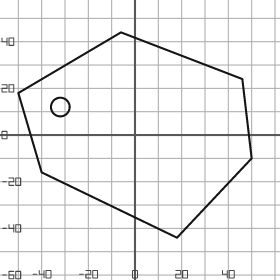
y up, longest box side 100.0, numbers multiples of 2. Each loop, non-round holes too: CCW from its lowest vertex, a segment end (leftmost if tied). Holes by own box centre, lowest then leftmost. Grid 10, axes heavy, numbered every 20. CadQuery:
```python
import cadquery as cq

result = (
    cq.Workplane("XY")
    .moveTo(18.0, -44.0)
    .lineTo(50.0, -10.0)
    .lineTo(46.0, 24.0)
    .lineTo(-6.0, 44.0)
    .lineTo(-50.0, 18.0)
    .lineTo(-40.0, -16.0)
    .close()
    .moveTo(-32.0, 12.0)
    .circle(4.0)
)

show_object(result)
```